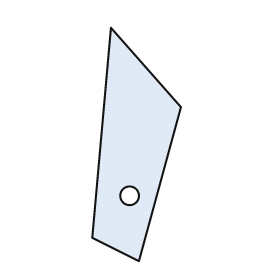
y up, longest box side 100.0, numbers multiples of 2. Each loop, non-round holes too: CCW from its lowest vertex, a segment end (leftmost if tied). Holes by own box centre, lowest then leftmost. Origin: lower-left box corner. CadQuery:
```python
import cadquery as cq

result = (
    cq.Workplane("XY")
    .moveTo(20.0, 0.0)
    .lineTo(38.0, 66.0)
    .lineTo(8.0, 100.0)
    .lineTo(0.0, 10.0)
    .close()
    .moveTo(16.0, 28.0)
    .circle(4.0)
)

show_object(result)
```